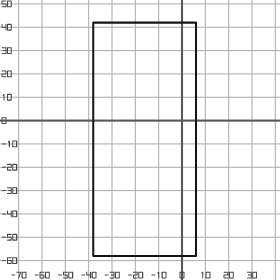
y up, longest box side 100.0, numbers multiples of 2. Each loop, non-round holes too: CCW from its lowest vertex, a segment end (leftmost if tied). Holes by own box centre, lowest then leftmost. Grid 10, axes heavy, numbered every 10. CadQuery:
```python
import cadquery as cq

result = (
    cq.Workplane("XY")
    .moveTo(-38.0, -58.0)
    .lineTo(6.0, -58.0)
    .lineTo(6.0, 42.0)
    .lineTo(-38.0, 42.0)
    .close()
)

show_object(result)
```